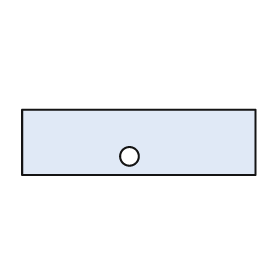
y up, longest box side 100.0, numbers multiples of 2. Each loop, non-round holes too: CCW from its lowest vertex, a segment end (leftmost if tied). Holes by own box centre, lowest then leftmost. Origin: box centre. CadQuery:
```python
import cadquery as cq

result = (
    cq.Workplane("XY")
    .moveTo(-50.0, -14.0)
    .lineTo(50.0, -14.0)
    .lineTo(50.0, 14.0)
    .lineTo(-50.0, 14.0)
    .close()
    .moveTo(-4.0, -6.0)
    .circle(4.0)
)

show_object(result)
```